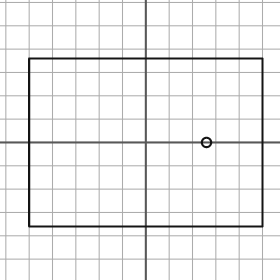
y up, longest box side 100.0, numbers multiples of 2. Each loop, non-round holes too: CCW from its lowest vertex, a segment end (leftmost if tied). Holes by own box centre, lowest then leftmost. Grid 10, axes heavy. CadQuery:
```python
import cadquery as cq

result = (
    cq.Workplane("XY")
    .moveTo(-50.0, -36.0)
    .lineTo(50.0, -36.0)
    .lineTo(50.0, 36.0)
    .lineTo(-50.0, 36.0)
    .close()
    .moveTo(26.0, 0.0)
    .circle(2.0)
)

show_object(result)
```